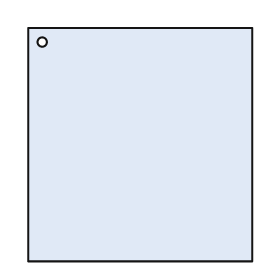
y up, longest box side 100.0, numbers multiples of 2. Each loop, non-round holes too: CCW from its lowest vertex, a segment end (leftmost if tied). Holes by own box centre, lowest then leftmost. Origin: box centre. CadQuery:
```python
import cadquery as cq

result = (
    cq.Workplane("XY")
    .moveTo(-48.0, -50.0)
    .lineTo(48.0, -50.0)
    .lineTo(48.0, 50.0)
    .lineTo(-48.0, 50.0)
    .close()
    .moveTo(-42.0, 44.0)
    .circle(2.0)
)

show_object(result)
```